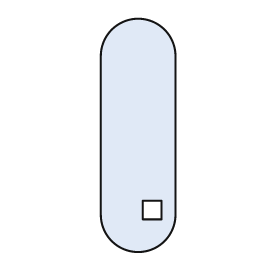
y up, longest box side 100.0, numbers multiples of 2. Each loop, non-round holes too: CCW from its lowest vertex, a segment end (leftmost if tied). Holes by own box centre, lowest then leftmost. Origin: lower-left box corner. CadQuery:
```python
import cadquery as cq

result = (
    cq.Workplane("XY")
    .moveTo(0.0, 16.0)
    .threePointArc((16.0, 0.0), (32.0, 16.0))
    .lineTo(32.0, 84.0)
    .threePointArc((16.0, 100.0), (0.0, 84.0))
    .close()
    .moveTo(18.0, 14.0)
    .lineTo(26.0, 14.0)
    .lineTo(26.0, 22.0)
    .lineTo(18.0, 22.0)
    .close()
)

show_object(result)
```